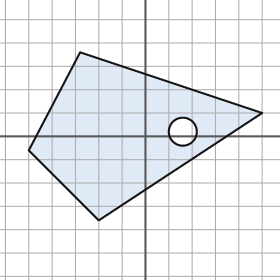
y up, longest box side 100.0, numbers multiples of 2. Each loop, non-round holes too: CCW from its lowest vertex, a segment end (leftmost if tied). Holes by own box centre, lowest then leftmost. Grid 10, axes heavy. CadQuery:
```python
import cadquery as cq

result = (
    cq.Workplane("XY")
    .moveTo(-20.0, -36.0)
    .lineTo(50.0, 10.0)
    .lineTo(-28.0, 36.0)
    .lineTo(-50.0, -6.0)
    .close()
    .moveTo(16.0, 2.0)
    .circle(6.0)
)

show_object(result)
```